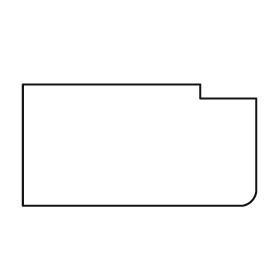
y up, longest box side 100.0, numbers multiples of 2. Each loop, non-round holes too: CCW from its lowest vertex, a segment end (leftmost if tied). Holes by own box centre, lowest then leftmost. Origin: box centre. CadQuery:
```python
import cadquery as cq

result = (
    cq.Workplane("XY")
    .moveTo(-50.0, -26.0)
    .lineTo(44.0, -26.0)
    .threePointArc((48.0, -24.0), (50.0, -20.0))
    .lineTo(50.0, 20.0)
    .lineTo(26.0, 20.0)
    .lineTo(26.0, 26.0)
    .lineTo(-50.0, 26.0)
    .close()
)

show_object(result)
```